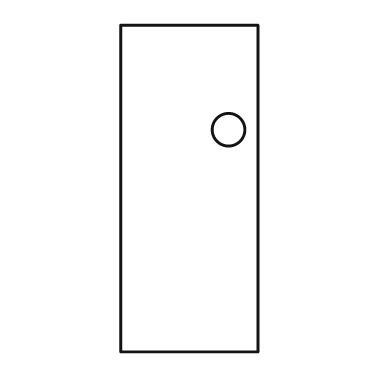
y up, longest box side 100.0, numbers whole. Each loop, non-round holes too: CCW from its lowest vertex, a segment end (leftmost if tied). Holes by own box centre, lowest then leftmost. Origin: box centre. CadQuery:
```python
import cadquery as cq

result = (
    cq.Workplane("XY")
    .moveTo(-21.0, -50.0)
    .lineTo(21.0, -50.0)
    .lineTo(21.0, 50.0)
    .lineTo(-21.0, 50.0)
    .close()
    .moveTo(12.0, 18.0)
    .circle(5.0)
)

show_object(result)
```